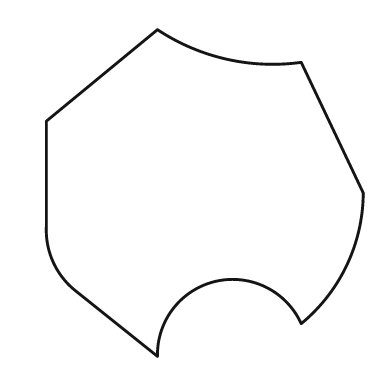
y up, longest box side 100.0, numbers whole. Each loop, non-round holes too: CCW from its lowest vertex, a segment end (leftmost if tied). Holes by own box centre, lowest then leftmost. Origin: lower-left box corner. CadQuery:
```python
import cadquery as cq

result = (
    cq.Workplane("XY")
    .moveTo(34.0, 0.0)
    .threePointArc((52.0, 23.0), (78.0, 10.0))
    .threePointArc((92.0, 28.0), (97.0, 50.0))
    .lineTo(78.0, 90.0)
    .threePointArc((55.0, 91.0), (34.0, 100.0))
    .lineTo(0.0, 72.0)
    .lineTo(0.0, 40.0)
    .threePointArc((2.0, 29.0), (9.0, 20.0))
    .close()
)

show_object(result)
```